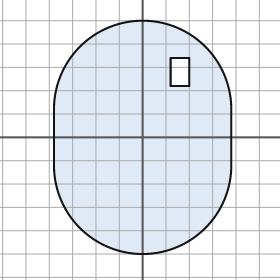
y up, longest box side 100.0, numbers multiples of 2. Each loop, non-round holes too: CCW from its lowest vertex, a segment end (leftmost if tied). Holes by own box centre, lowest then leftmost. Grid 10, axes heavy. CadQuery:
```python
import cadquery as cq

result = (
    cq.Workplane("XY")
    .moveTo(-38.0, -12.0)
    .threePointArc((0.0, -50.0), (38.0, -12.0))
    .lineTo(38.0, 12.0)
    .threePointArc((0.0, 50.0), (-38.0, 12.0))
    .close()
    .moveTo(12.0, 22.0)
    .lineTo(20.0, 22.0)
    .lineTo(20.0, 34.0)
    .lineTo(12.0, 34.0)
    .close()
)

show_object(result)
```